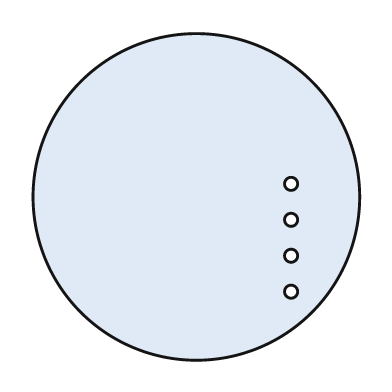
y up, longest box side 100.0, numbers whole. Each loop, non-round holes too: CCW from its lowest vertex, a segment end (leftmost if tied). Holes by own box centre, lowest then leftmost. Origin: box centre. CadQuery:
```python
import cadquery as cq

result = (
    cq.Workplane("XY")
    .moveTo(0.0, 0.0)
    .circle(50.0)
    .moveTo(29.0, -29.0)
    .circle(2.0)
    .moveTo(29.0, -18.0)
    .circle(2.0)
    .moveTo(29.0, -7.0)
    .circle(2.0)
    .moveTo(29.0, 4.0)
    .circle(2.0)
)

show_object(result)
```